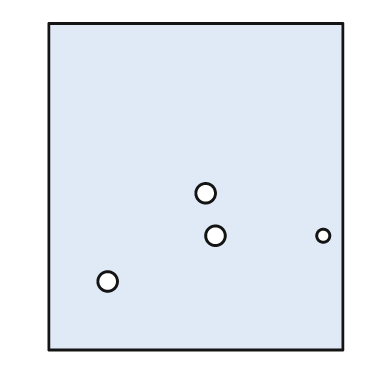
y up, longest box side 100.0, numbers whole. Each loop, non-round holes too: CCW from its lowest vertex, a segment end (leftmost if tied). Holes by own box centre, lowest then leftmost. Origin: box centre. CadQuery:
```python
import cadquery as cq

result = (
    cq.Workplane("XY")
    .moveTo(-45.0, -50.0)
    .lineTo(45.0, -50.0)
    .lineTo(45.0, 50.0)
    .lineTo(-45.0, 50.0)
    .close()
    .moveTo(-27.0, -29.0)
    .circle(3.0)
    .moveTo(6.0, -15.0)
    .circle(3.0)
    .moveTo(39.0, -15.0)
    .circle(2.0)
    .moveTo(3.0, -2.0)
    .circle(3.0)
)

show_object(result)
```